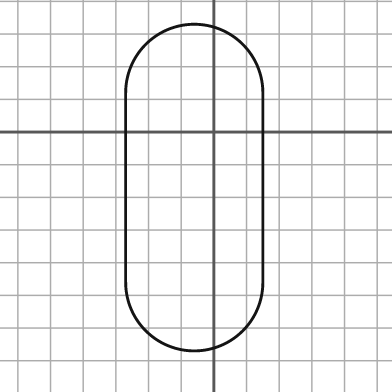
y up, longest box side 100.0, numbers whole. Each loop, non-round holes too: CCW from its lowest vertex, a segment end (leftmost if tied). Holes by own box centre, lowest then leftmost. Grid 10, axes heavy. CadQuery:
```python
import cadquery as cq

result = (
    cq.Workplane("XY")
    .moveTo(-27.0, -46.0)
    .threePointArc((-6.0, -67.0), (15.0, -46.0))
    .lineTo(15.0, 12.0)
    .threePointArc((-6.0, 33.0), (-27.0, 12.0))
    .close()
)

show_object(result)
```